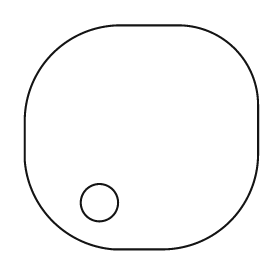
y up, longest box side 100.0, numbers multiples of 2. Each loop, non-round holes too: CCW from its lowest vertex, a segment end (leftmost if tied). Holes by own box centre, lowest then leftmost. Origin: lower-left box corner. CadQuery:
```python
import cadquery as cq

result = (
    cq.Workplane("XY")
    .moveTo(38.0, 0.0)
    .lineTo(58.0, 0.0)
    .threePointArc((88.0, 12.0), (100.0, 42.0))
    .lineTo(100.0, 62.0)
    .threePointArc((90.0, 86.0), (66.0, 96.0))
    .lineTo(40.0, 96.0)
    .threePointArc((12.0, 84.0), (0.0, 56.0))
    .lineTo(0.0, 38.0)
    .threePointArc((12.0, 12.0), (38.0, 0.0))
    .close()
    .moveTo(32.0, 20.0)
    .circle(8.0)
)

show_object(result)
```